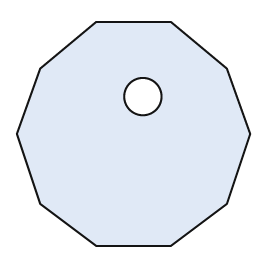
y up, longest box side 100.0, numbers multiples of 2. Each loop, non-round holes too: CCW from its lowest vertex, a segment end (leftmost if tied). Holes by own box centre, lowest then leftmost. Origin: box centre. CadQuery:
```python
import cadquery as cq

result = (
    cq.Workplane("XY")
    .moveTo(-16.0, -48.0)
    .lineTo(16.0, -48.0)
    .lineTo(40.0, -30.0)
    .lineTo(50.0, 0.0)
    .lineTo(40.0, 28.0)
    .lineTo(16.0, 48.0)
    .lineTo(-16.0, 48.0)
    .lineTo(-40.0, 28.0)
    .lineTo(-50.0, 0.0)
    .lineTo(-40.0, -30.0)
    .close()
    .moveTo(4.0, 16.0)
    .circle(8.0)
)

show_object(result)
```